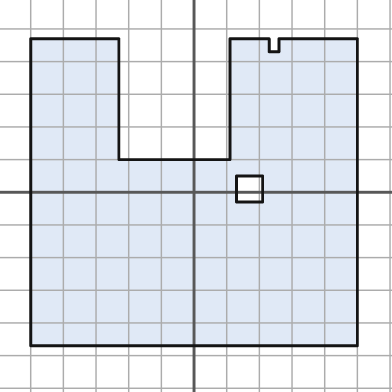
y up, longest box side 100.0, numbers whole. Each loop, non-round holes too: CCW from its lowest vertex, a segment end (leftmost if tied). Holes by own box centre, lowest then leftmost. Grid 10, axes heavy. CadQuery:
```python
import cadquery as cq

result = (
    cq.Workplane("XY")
    .moveTo(-50.0, -47.0)
    .lineTo(50.0, -47.0)
    .lineTo(50.0, 47.0)
    .lineTo(26.0, 47.0)
    .lineTo(26.0, 43.0)
    .lineTo(23.0, 43.0)
    .lineTo(23.0, 47.0)
    .lineTo(11.0, 47.0)
    .lineTo(11.0, 10.0)
    .lineTo(-23.0, 10.0)
    .lineTo(-23.0, 47.0)
    .lineTo(-50.0, 47.0)
    .close()
    .moveTo(13.0, -3.0)
    .lineTo(21.0, -3.0)
    .lineTo(21.0, 5.0)
    .lineTo(13.0, 5.0)
    .close()
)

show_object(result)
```